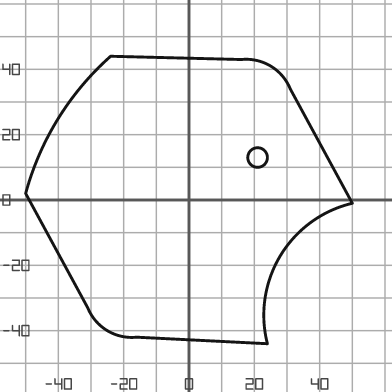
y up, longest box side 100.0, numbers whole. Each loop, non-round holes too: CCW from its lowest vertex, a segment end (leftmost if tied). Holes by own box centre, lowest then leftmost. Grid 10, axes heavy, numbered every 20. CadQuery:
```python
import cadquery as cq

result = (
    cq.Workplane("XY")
    .moveTo(24.0, -44.0)
    .threePointArc((28.0, -17.0), (50.0, -1.0))
    .lineTo(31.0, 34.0)
    .threePointArc((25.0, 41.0), (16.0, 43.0))
    .lineTo(-24.0, 44.0)
    .threePointArc((-40.0, 25.0), (-50.0, 2.0))
    .lineTo(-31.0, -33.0)
    .threePointArc((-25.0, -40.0), (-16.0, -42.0))
    .close()
    .moveTo(21.0, 13.0)
    .circle(3.0)
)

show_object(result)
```